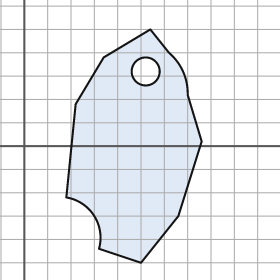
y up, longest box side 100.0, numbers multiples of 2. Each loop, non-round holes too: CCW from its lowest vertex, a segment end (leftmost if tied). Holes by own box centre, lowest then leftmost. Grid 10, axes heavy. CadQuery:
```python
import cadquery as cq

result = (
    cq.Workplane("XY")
    .moveTo(50.0, -50.0)
    .lineTo(66.0, -30.0)
    .lineTo(76.0, 2.0)
    .lineTo(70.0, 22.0)
    .threePointArc((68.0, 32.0), (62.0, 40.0))
    .lineTo(54.0, 50.0)
    .lineTo(34.0, 38.0)
    .lineTo(22.0, 18.0)
    .lineTo(18.0, -22.0)
    .threePointArc((30.0, -30.0), (32.0, -44.0))
    .close()
    .moveTo(52.0, 32.0)
    .circle(6.0)
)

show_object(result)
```